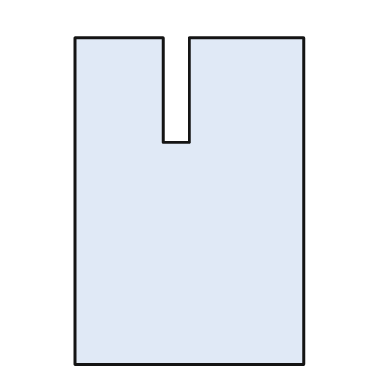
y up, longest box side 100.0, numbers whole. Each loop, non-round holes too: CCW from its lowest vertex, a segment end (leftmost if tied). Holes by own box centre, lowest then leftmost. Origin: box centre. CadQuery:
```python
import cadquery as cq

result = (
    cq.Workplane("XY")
    .moveTo(-35.0, -50.0)
    .lineTo(35.0, -50.0)
    .lineTo(35.0, 50.0)
    .lineTo(0.0, 50.0)
    .lineTo(0.0, 18.0)
    .lineTo(-8.0, 18.0)
    .lineTo(-8.0, 50.0)
    .lineTo(-35.0, 50.0)
    .close()
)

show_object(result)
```